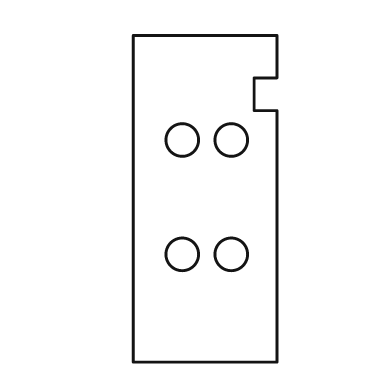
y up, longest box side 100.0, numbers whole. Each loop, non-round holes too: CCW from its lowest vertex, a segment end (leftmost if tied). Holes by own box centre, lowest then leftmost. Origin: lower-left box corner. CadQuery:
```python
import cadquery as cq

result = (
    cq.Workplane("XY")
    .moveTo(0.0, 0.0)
    .lineTo(44.0, 0.0)
    .lineTo(44.0, 77.0)
    .lineTo(37.0, 77.0)
    .lineTo(37.0, 87.0)
    .lineTo(44.0, 87.0)
    .lineTo(44.0, 100.0)
    .lineTo(0.0, 100.0)
    .close()
    .moveTo(15.0, 33.0)
    .circle(5.0)
    .moveTo(30.0, 33.0)
    .circle(5.0)
    .moveTo(15.0, 68.0)
    .circle(5.0)
    .moveTo(30.0, 68.0)
    .circle(5.0)
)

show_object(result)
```